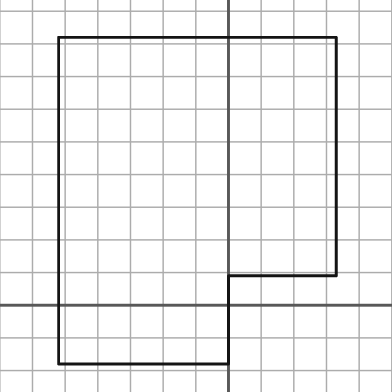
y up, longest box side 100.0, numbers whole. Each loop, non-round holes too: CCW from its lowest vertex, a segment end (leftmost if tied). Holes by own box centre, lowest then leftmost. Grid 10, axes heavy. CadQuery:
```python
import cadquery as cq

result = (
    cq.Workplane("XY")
    .moveTo(-52.0, -18.0)
    .lineTo(0.0, -18.0)
    .lineTo(0.0, 9.0)
    .lineTo(33.0, 9.0)
    .lineTo(33.0, 82.0)
    .lineTo(-52.0, 82.0)
    .close()
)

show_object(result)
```